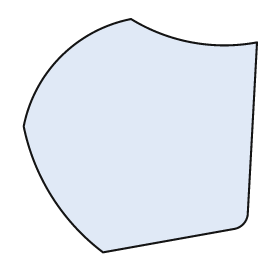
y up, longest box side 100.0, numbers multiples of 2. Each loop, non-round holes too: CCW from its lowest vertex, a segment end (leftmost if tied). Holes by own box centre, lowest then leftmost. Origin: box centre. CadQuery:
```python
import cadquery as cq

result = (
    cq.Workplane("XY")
    .moveTo(-16.0, -50.0)
    .lineTo(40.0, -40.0)
    .threePointArc((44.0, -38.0), (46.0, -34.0))
    .lineTo(50.0, 40.0)
    .threePointArc((22.0, 40.0), (-4.0, 50.0))
    .threePointArc((-34.0, 34.0), (-50.0, 4.0))
    .threePointArc((-38.0, -26.0), (-16.0, -50.0))
    .close()
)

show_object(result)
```